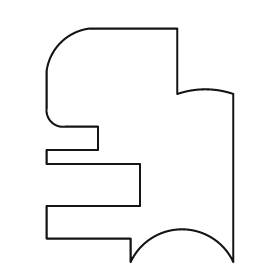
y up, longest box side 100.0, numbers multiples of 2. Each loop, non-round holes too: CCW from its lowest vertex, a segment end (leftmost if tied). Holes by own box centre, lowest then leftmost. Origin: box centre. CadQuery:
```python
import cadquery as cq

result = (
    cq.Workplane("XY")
    .moveTo(-4.0, -50.0)
    .threePointArc((18.0, -36.0), (40.0, -50.0))
    .lineTo(40.0, 22.0)
    .threePointArc((28.0, 24.0), (16.0, 22.0))
    .lineTo(16.0, 50.0)
    .lineTo(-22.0, 50.0)
    .threePointArc((-34.0, 44.0), (-40.0, 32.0))
    .lineTo(-40.0, 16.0)
    .threePointArc((-38.0, 10.0), (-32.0, 8.0))
    .lineTo(-18.0, 8.0)
    .lineTo(-18.0, -2.0)
    .lineTo(-40.0, -2.0)
    .lineTo(-40.0, -8.0)
    .lineTo(0.0, -8.0)
    .lineTo(0.0, -26.0)
    .lineTo(-40.0, -26.0)
    .lineTo(-40.0, -40.0)
    .lineTo(-4.0, -40.0)
    .close()
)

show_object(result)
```